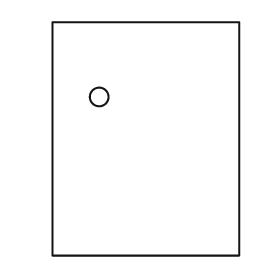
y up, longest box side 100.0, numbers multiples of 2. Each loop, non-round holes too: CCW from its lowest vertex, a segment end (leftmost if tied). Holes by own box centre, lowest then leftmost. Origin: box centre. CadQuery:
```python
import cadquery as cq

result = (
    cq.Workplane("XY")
    .moveTo(-40.0, -50.0)
    .lineTo(40.0, -50.0)
    .lineTo(40.0, 50.0)
    .lineTo(-40.0, 50.0)
    .close()
    .moveTo(-20.0, 18.0)
    .circle(4.0)
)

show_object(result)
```